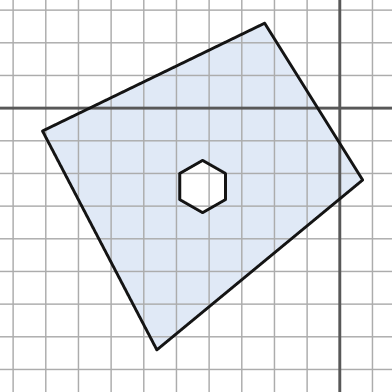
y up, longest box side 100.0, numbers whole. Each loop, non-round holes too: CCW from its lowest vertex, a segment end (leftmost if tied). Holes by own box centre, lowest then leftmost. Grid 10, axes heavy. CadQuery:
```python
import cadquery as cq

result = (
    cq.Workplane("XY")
    .moveTo(-56.0, -74.0)
    .lineTo(7.0, -22.0)
    .lineTo(-23.0, 26.0)
    .lineTo(-91.0, -7.0)
    .close()
    .moveTo(-42.0, -32.0)
    .lineTo(-35.0, -28.0)
    .lineTo(-35.0, -20.0)
    .lineTo(-42.0, -16.0)
    .lineTo(-49.0, -20.0)
    .lineTo(-49.0, -28.0)
    .close()
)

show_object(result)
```